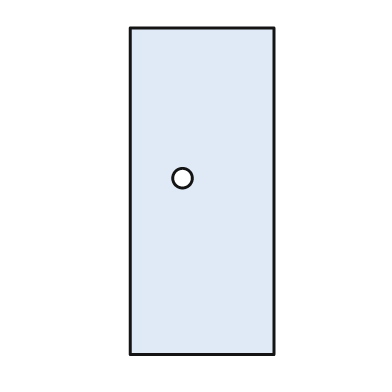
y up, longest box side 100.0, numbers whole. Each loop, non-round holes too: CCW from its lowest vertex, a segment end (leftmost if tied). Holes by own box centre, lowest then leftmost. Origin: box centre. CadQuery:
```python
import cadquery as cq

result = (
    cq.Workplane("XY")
    .moveTo(-22.0, -50.0)
    .lineTo(22.0, -50.0)
    .lineTo(22.0, 50.0)
    .lineTo(-22.0, 50.0)
    .close()
    .moveTo(-6.0, 4.0)
    .circle(3.0)
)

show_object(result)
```